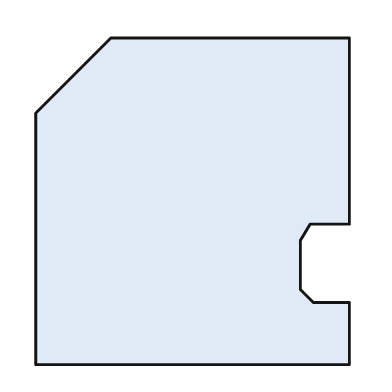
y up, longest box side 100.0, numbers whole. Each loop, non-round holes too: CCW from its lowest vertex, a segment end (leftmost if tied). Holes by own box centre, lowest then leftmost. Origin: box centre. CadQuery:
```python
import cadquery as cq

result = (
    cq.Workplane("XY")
    .moveTo(-48.0, -50.0)
    .lineTo(48.0, -50.0)
    .lineTo(48.0, -31.0)
    .lineTo(37.0, -31.0)
    .lineTo(33.0, -27.0)
    .lineTo(33.0, -12.0)
    .lineTo(36.0, -7.0)
    .lineTo(48.0, -7.0)
    .lineTo(48.0, 50.0)
    .lineTo(-25.0, 50.0)
    .lineTo(-48.0, 27.0)
    .close()
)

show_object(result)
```